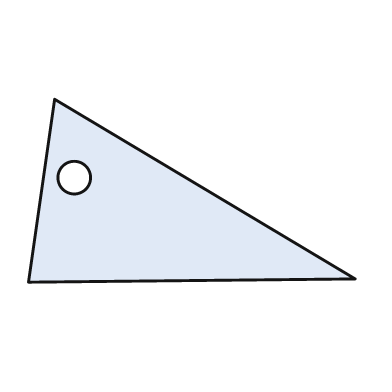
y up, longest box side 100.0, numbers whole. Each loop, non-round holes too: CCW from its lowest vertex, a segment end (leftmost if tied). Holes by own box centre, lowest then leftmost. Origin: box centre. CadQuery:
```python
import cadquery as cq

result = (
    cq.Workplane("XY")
    .moveTo(-50.0, -28.0)
    .lineTo(50.0, -27.0)
    .lineTo(-42.0, 28.0)
    .close()
    .moveTo(-36.0, 4.0)
    .circle(5.0)
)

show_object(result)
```